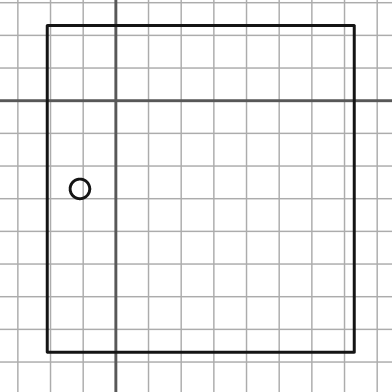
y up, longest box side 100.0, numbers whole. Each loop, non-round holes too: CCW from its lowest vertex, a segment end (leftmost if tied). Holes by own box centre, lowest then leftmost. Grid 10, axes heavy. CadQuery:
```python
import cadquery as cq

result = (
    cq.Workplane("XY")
    .moveTo(-21.0, -77.0)
    .lineTo(73.0, -77.0)
    .lineTo(73.0, 23.0)
    .lineTo(-21.0, 23.0)
    .close()
    .moveTo(-11.0, -27.0)
    .circle(3.0)
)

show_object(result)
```